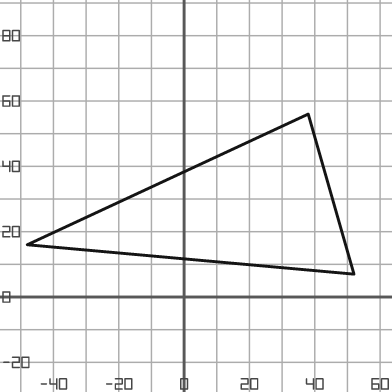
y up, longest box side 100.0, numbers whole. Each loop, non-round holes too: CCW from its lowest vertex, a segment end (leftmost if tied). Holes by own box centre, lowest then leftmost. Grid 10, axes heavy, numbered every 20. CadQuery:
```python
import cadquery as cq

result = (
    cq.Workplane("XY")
    .moveTo(52.0, 7.0)
    .lineTo(38.0, 56.0)
    .lineTo(-48.0, 16.0)
    .close()
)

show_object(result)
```